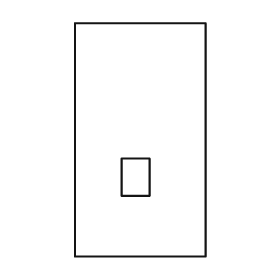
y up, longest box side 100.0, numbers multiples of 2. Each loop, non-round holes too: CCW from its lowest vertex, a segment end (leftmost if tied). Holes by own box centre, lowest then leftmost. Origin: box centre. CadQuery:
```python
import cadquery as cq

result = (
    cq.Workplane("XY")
    .moveTo(-28.0, -50.0)
    .lineTo(28.0, -50.0)
    .lineTo(28.0, 50.0)
    .lineTo(-28.0, 50.0)
    .close()
    .moveTo(-8.0, -24.0)
    .lineTo(4.0, -24.0)
    .lineTo(4.0, -8.0)
    .lineTo(-8.0, -8.0)
    .close()
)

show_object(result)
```